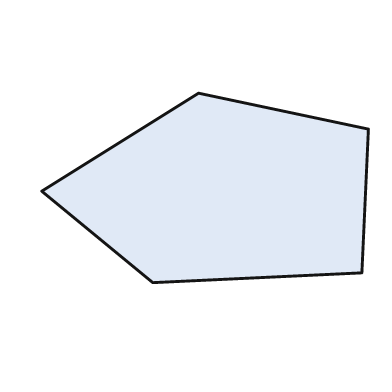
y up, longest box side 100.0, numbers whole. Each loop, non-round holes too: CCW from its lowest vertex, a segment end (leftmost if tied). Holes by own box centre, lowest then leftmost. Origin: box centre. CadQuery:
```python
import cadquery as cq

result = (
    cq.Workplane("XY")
    .moveTo(-16.0, -29.0)
    .lineTo(48.0, -26.0)
    .lineTo(50.0, 18.0)
    .lineTo(-2.0, 29.0)
    .lineTo(-50.0, -1.0)
    .close()
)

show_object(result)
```